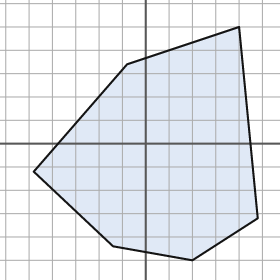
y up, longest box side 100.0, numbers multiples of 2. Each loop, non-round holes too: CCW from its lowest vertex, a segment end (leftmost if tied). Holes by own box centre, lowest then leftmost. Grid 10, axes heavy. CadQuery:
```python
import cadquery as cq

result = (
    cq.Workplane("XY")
    .moveTo(20.0, -50.0)
    .lineTo(48.0, -32.0)
    .lineTo(40.0, 50.0)
    .lineTo(-8.0, 34.0)
    .lineTo(-48.0, -12.0)
    .lineTo(-14.0, -44.0)
    .close()
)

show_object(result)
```